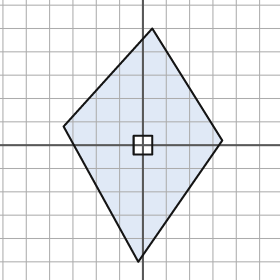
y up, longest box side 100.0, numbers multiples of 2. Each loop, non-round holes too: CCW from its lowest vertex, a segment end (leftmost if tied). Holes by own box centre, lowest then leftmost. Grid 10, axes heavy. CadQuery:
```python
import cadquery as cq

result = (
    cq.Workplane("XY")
    .moveTo(-2.0, -50.0)
    .lineTo(34.0, 2.0)
    .lineTo(4.0, 50.0)
    .lineTo(-34.0, 8.0)
    .close()
    .moveTo(-4.0, -4.0)
    .lineTo(4.0, -4.0)
    .lineTo(4.0, 4.0)
    .lineTo(-4.0, 4.0)
    .close()
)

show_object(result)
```